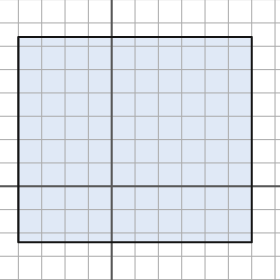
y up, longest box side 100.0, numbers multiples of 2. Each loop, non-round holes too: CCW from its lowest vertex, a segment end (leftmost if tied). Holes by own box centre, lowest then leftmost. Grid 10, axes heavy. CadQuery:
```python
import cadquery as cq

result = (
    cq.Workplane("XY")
    .moveTo(-40.0, -24.0)
    .lineTo(60.0, -24.0)
    .lineTo(60.0, 64.0)
    .lineTo(-40.0, 64.0)
    .close()
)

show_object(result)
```